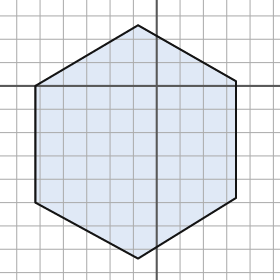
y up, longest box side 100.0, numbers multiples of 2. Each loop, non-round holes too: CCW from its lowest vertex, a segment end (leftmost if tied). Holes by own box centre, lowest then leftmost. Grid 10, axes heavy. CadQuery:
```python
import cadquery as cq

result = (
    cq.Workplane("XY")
    .moveTo(-8.0, -74.0)
    .lineTo(34.0, -48.0)
    .lineTo(34.0, 2.0)
    .lineTo(-8.0, 26.0)
    .lineTo(-52.0, 0.0)
    .lineTo(-52.0, -50.0)
    .close()
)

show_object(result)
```